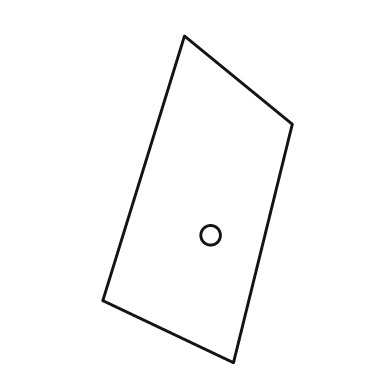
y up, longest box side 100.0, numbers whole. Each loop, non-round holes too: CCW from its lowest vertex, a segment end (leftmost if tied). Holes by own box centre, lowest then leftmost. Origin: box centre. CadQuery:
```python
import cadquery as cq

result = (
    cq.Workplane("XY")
    .moveTo(11.0, -50.0)
    .lineTo(29.0, 23.0)
    .lineTo(-4.0, 50.0)
    .lineTo(-29.0, -31.0)
    .close()
    .moveTo(4.0, -11.0)
    .circle(3.0)
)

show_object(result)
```